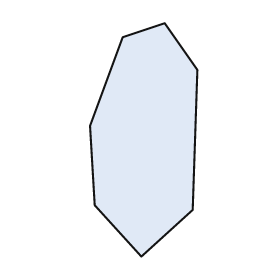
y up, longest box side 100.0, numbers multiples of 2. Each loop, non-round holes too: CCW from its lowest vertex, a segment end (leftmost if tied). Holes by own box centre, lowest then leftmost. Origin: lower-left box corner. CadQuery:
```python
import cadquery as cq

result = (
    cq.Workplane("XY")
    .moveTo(22.0, 0.0)
    .lineTo(44.0, 20.0)
    .lineTo(46.0, 80.0)
    .lineTo(32.0, 100.0)
    .lineTo(14.0, 94.0)
    .lineTo(0.0, 56.0)
    .lineTo(2.0, 22.0)
    .close()
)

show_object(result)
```